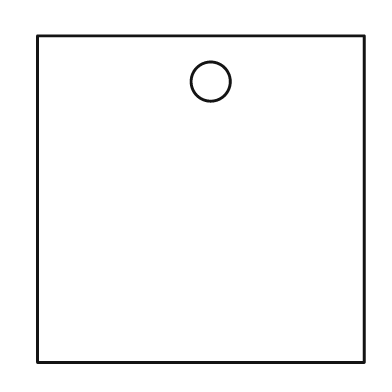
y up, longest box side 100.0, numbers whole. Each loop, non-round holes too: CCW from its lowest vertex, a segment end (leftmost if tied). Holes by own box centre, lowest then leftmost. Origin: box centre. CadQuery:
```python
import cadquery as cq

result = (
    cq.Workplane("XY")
    .moveTo(-50.0, -50.0)
    .lineTo(50.0, -50.0)
    .lineTo(50.0, 50.0)
    .lineTo(-50.0, 50.0)
    .close()
    .moveTo(3.0, 36.0)
    .circle(6.0)
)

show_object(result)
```